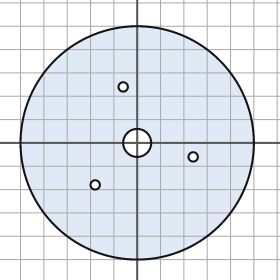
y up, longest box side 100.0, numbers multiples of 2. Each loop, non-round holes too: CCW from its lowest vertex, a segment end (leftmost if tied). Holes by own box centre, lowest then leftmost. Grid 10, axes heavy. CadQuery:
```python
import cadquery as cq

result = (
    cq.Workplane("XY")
    .moveTo(0.0, 0.0)
    .circle(50.0)
    .moveTo(-18.0, -18.0)
    .circle(2.0)
    .moveTo(24.0, -6.0)
    .circle(2.0)
    .moveTo(0.0, 0.0)
    .circle(6.0)
    .moveTo(-6.0, 24.0)
    .circle(2.0)
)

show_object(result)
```